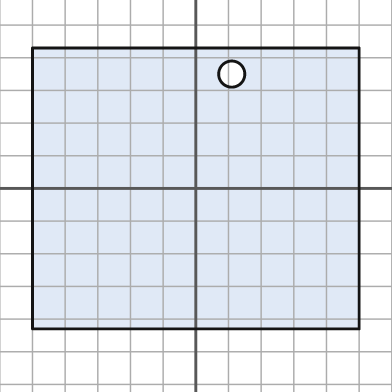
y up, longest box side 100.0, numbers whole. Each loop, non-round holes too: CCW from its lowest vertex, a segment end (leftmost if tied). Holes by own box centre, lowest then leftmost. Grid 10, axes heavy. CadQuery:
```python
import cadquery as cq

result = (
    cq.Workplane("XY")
    .moveTo(-50.0, -43.0)
    .lineTo(50.0, -43.0)
    .lineTo(50.0, 43.0)
    .lineTo(-50.0, 43.0)
    .close()
    .moveTo(11.0, 35.0)
    .circle(4.0)
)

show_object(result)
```